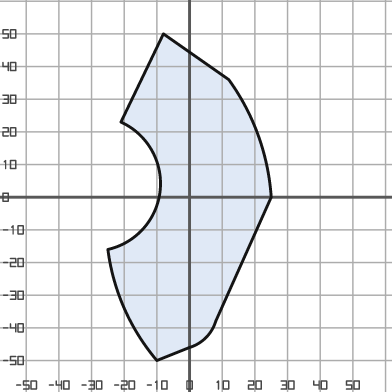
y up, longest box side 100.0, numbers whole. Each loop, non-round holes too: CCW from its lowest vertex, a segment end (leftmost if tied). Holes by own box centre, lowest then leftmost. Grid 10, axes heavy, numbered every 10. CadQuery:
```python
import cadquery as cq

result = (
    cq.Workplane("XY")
    .moveTo(-10.0, -50.0)
    .lineTo(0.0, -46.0)
    .threePointArc((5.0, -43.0), (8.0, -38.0))
    .lineTo(25.0, 0.0)
    .threePointArc((21.0, 19.0), (12.0, 36.0))
    .lineTo(-8.0, 50.0)
    .lineTo(-21.0, 23.0)
    .threePointArc((-9.0, 2.0), (-25.0, -16.0))
    .threePointArc((-20.0, -34.0), (-10.0, -50.0))
    .close()
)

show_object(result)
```